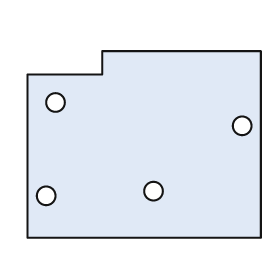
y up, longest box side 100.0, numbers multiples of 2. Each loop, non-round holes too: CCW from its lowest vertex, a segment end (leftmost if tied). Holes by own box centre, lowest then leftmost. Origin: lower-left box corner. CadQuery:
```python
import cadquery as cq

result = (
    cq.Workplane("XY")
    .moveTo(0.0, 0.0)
    .lineTo(100.0, 0.0)
    .lineTo(100.0, 80.0)
    .lineTo(32.0, 80.0)
    .lineTo(32.0, 70.0)
    .lineTo(0.0, 70.0)
    .close()
    .moveTo(8.0, 18.0)
    .circle(4.0)
    .moveTo(54.0, 20.0)
    .circle(4.0)
    .moveTo(92.0, 48.0)
    .circle(4.0)
    .moveTo(12.0, 58.0)
    .circle(4.0)
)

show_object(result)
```